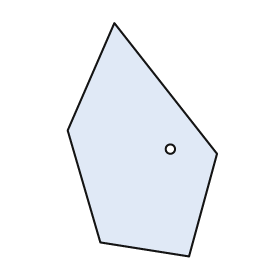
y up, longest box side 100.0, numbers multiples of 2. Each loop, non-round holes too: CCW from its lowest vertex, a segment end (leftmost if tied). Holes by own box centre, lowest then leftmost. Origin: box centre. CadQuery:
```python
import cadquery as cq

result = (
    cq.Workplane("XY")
    .moveTo(20.0, -50.0)
    .lineTo(32.0, -6.0)
    .lineTo(-12.0, 50.0)
    .lineTo(-32.0, 4.0)
    .lineTo(-18.0, -44.0)
    .close()
    .moveTo(12.0, -4.0)
    .circle(2.0)
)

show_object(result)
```